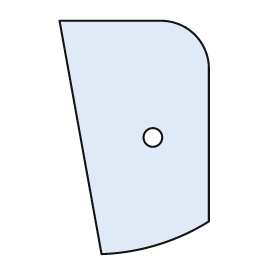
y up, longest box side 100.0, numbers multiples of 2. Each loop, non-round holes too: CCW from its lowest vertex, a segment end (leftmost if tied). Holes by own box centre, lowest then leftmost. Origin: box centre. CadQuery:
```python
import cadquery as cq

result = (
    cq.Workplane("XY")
    .moveTo(-14.0, -50.0)
    .threePointArc((10.0, -46.0), (32.0, -36.0))
    .lineTo(32.0, 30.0)
    .threePointArc((26.0, 44.0), (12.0, 50.0))
    .lineTo(-32.0, 50.0)
    .close()
    .moveTo(8.0, 0.0)
    .circle(4.0)
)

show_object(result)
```